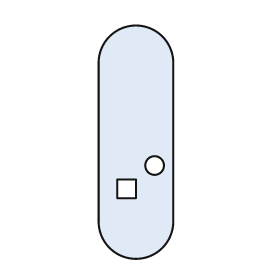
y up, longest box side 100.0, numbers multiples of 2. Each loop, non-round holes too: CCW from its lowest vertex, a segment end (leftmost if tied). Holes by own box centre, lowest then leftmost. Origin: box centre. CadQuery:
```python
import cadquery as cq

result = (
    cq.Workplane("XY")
    .moveTo(-16.0, -34.0)
    .threePointArc((0.0, -50.0), (16.0, -34.0))
    .lineTo(16.0, 34.0)
    .threePointArc((0.0, 50.0), (-16.0, 34.0))
    .close()
    .moveTo(-8.0, -24.0)
    .lineTo(0.0, -24.0)
    .lineTo(0.0, -16.0)
    .lineTo(-8.0, -16.0)
    .close()
    .moveTo(8.0, -10.0)
    .circle(4.0)
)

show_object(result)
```